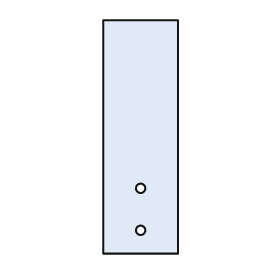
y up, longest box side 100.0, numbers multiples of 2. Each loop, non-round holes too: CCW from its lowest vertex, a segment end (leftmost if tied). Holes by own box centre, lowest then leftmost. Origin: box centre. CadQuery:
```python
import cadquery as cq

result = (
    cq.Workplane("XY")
    .moveTo(-16.0, -50.0)
    .lineTo(16.0, -50.0)
    .lineTo(16.0, 50.0)
    .lineTo(-16.0, 50.0)
    .close()
    .moveTo(0.0, -40.0)
    .circle(2.0)
    .moveTo(0.0, -22.0)
    .circle(2.0)
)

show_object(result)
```